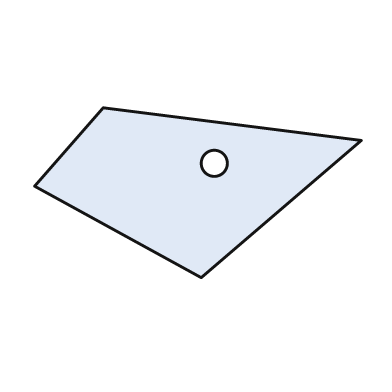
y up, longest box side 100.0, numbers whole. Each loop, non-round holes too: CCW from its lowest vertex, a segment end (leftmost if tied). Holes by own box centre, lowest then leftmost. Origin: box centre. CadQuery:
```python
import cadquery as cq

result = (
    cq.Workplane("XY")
    .moveTo(1.0, -26.0)
    .lineTo(50.0, 16.0)
    .lineTo(-29.0, 26.0)
    .lineTo(-50.0, 2.0)
    .close()
    .moveTo(5.0, 9.0)
    .circle(4.0)
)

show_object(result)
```